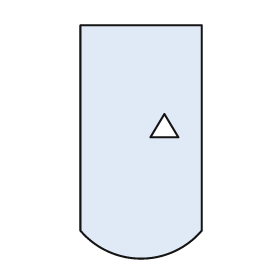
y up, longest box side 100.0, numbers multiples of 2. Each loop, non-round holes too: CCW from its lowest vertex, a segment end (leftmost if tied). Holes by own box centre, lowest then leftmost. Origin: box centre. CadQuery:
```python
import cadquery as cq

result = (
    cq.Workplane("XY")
    .moveTo(-26.0, -38.0)
    .threePointArc((0.0, -50.0), (26.0, -38.0))
    .lineTo(26.0, 50.0)
    .lineTo(-26.0, 50.0)
    .close()
    .moveTo(4.0, 2.0)
    .lineTo(16.0, 2.0)
    .lineTo(10.0, 12.0)
    .close()
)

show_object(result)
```